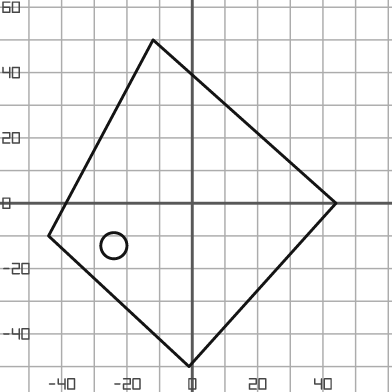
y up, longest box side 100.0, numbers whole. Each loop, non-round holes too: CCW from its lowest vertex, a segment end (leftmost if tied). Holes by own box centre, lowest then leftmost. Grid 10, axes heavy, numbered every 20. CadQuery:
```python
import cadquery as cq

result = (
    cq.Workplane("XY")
    .moveTo(-1.0, -50.0)
    .lineTo(44.0, 0.0)
    .lineTo(-12.0, 50.0)
    .lineTo(-44.0, -10.0)
    .close()
    .moveTo(-24.0, -13.0)
    .circle(4.0)
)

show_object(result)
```